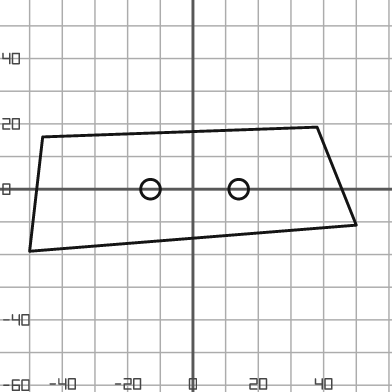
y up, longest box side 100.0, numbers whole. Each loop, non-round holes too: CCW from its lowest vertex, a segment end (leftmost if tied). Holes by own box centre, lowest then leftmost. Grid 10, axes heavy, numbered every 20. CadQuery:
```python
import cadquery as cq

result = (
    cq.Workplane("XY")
    .moveTo(-50.0, -19.0)
    .lineTo(50.0, -11.0)
    .lineTo(38.0, 19.0)
    .lineTo(-46.0, 16.0)
    .close()
    .moveTo(-13.0, 0.0)
    .circle(3.0)
    .moveTo(14.0, 0.0)
    .circle(3.0)
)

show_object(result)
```